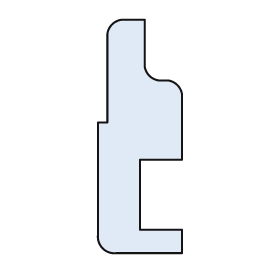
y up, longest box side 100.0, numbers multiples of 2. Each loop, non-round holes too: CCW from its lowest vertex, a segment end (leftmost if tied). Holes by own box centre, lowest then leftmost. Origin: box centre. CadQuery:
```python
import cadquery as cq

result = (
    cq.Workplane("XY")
    .moveTo(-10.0, -50.0)
    .lineTo(18.0, -50.0)
    .lineTo(18.0, -40.0)
    .lineTo(0.0, -40.0)
    .lineTo(0.0, -10.0)
    .lineTo(18.0, -10.0)
    .lineTo(18.0, 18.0)
    .threePointArc((16.0, 22.0), (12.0, 24.0))
    .lineTo(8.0, 24.0)
    .threePointArc((4.0, 26.0), (2.0, 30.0))
    .lineTo(2.0, 50.0)
    .lineTo(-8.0, 50.0)
    .threePointArc((-12.0, 48.0), (-14.0, 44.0))
    .lineTo(-14.0, 6.0)
    .lineTo(-18.0, 6.0)
    .lineTo(-18.0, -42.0)
    .threePointArc((-16.0, -48.0), (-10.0, -50.0))
    .close()
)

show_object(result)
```